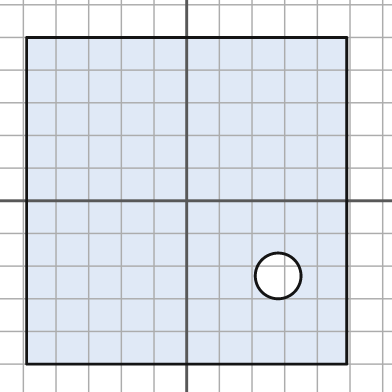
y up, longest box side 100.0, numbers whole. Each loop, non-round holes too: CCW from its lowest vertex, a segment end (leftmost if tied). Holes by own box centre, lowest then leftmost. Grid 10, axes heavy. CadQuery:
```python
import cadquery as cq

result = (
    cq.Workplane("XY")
    .moveTo(-49.0, -50.0)
    .lineTo(49.0, -50.0)
    .lineTo(49.0, 50.0)
    .lineTo(-49.0, 50.0)
    .close()
    .moveTo(28.0, -23.0)
    .circle(7.0)
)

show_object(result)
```